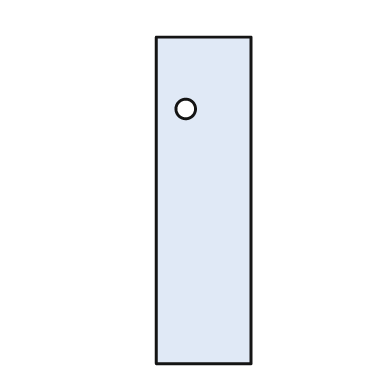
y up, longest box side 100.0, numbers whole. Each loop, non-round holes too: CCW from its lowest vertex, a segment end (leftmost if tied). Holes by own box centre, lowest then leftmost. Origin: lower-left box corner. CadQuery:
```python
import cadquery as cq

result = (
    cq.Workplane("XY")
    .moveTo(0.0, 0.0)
    .lineTo(29.0, 0.0)
    .lineTo(29.0, 100.0)
    .lineTo(0.0, 100.0)
    .close()
    .moveTo(9.0, 78.0)
    .circle(3.0)
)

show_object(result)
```